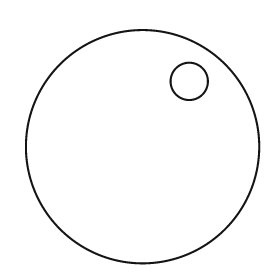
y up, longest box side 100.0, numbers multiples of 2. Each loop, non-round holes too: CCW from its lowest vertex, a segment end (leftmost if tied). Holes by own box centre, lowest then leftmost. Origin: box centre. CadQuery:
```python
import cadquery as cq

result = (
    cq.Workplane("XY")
    .moveTo(0.0, 0.0)
    .circle(50.0)
    .moveTo(20.0, 28.0)
    .circle(8.0)
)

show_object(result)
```